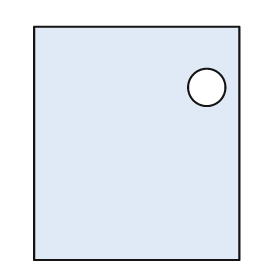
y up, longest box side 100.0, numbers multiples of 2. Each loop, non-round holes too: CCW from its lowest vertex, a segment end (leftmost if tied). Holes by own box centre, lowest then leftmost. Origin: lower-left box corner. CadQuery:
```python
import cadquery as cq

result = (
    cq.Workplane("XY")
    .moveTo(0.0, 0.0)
    .lineTo(88.0, 0.0)
    .lineTo(88.0, 100.0)
    .lineTo(0.0, 100.0)
    .close()
    .moveTo(74.0, 74.0)
    .circle(8.0)
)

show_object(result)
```